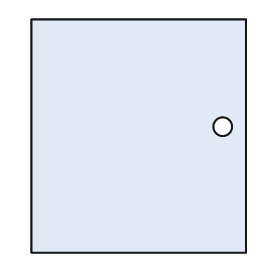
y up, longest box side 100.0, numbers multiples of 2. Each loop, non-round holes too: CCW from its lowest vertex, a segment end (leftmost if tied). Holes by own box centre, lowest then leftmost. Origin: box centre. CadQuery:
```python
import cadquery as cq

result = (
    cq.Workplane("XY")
    .moveTo(-46.0, -50.0)
    .lineTo(46.0, -50.0)
    .lineTo(46.0, 50.0)
    .lineTo(-46.0, 50.0)
    .close()
    .moveTo(36.0, 4.0)
    .circle(4.0)
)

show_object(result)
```